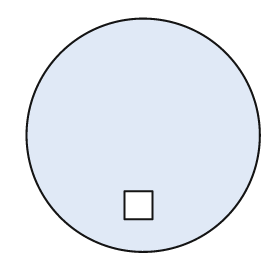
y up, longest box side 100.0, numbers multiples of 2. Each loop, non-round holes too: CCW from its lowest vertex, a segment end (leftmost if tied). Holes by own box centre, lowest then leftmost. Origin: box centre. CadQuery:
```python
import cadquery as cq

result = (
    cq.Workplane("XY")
    .moveTo(0.0, 0.0)
    .circle(50.0)
    .moveTo(-8.0, -36.0)
    .lineTo(4.0, -36.0)
    .lineTo(4.0, -24.0)
    .lineTo(-8.0, -24.0)
    .close()
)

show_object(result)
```